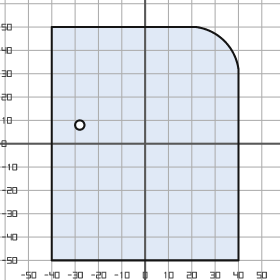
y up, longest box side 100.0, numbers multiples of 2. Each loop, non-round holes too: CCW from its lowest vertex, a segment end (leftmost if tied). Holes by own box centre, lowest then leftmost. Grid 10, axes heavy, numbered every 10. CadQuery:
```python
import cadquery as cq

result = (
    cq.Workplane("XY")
    .moveTo(-40.0, -50.0)
    .lineTo(40.0, -50.0)
    .lineTo(40.0, 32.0)
    .threePointArc((34.0, 44.0), (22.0, 50.0))
    .lineTo(-40.0, 50.0)
    .close()
    .moveTo(-28.0, 8.0)
    .circle(2.0)
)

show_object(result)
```